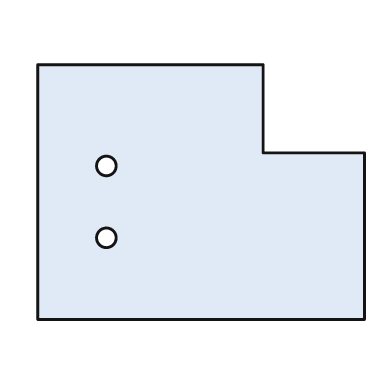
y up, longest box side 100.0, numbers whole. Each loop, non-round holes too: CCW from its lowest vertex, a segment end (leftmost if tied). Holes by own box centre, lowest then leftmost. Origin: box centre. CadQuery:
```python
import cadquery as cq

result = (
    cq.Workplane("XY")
    .moveTo(-50.0, -39.0)
    .lineTo(50.0, -39.0)
    .lineTo(50.0, 12.0)
    .lineTo(19.0, 12.0)
    .lineTo(19.0, 39.0)
    .lineTo(-50.0, 39.0)
    .close()
    .moveTo(-29.0, -14.0)
    .circle(3.0)
    .moveTo(-29.0, 8.0)
    .circle(3.0)
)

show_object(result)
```